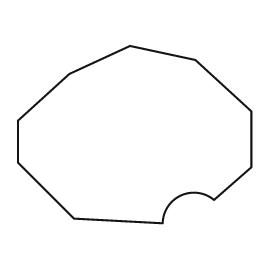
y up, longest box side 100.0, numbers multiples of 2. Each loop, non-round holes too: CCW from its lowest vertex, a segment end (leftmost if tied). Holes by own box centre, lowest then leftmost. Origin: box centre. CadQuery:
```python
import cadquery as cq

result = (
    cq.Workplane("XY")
    .moveTo(12.0, -38.0)
    .threePointArc((20.0, -26.0), (34.0, -28.0))
    .lineTo(50.0, -14.0)
    .lineTo(50.0, 10.0)
    .lineTo(26.0, 32.0)
    .lineTo(-2.0, 38.0)
    .lineTo(-28.0, 26.0)
    .lineTo(-50.0, 6.0)
    .lineTo(-50.0, -12.0)
    .lineTo(-26.0, -36.0)
    .close()
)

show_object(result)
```